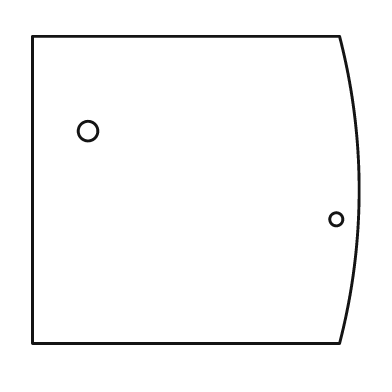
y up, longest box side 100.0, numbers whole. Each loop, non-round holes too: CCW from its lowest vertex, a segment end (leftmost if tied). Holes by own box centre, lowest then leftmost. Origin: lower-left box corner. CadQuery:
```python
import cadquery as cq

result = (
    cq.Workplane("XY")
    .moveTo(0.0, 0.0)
    .lineTo(94.0, 0.0)
    .threePointArc((100.0, 47.0), (94.0, 94.0))
    .lineTo(0.0, 94.0)
    .close()
    .moveTo(93.0, 38.0)
    .circle(2.0)
    .moveTo(17.0, 65.0)
    .circle(3.0)
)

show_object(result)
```